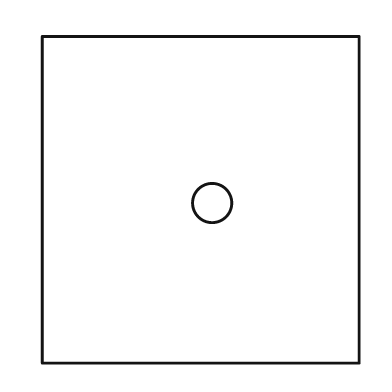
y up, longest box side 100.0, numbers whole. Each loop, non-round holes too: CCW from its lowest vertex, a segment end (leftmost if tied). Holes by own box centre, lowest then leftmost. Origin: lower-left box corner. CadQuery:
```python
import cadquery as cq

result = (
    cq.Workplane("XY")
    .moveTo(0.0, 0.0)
    .lineTo(97.0, 0.0)
    .lineTo(97.0, 100.0)
    .lineTo(0.0, 100.0)
    .close()
    .moveTo(52.0, 49.0)
    .circle(6.0)
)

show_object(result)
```